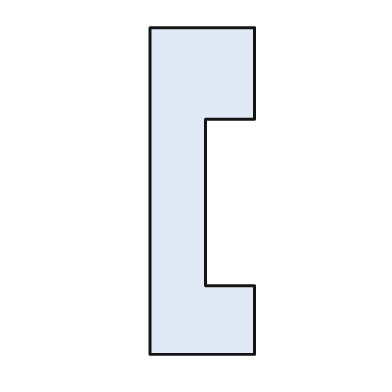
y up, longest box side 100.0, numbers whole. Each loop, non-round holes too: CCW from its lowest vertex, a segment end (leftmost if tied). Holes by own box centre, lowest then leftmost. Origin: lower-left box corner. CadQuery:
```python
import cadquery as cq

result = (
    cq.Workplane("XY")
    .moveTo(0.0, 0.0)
    .lineTo(32.0, 0.0)
    .lineTo(32.0, 21.0)
    .lineTo(17.0, 21.0)
    .lineTo(17.0, 72.0)
    .lineTo(32.0, 72.0)
    .lineTo(32.0, 100.0)
    .lineTo(0.0, 100.0)
    .close()
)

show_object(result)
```